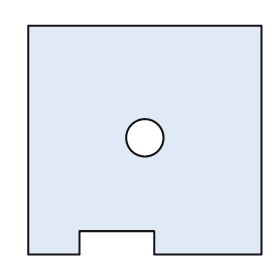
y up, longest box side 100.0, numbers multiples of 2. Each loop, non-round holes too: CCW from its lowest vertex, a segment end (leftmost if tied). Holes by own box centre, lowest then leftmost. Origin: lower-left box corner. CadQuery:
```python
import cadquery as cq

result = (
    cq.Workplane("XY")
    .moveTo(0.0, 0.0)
    .lineTo(22.0, 0.0)
    .lineTo(22.0, 10.0)
    .lineTo(54.0, 10.0)
    .lineTo(54.0, 0.0)
    .lineTo(100.0, 0.0)
    .lineTo(100.0, 98.0)
    .lineTo(0.0, 98.0)
    .close()
    .moveTo(50.0, 50.0)
    .circle(8.0)
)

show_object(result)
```